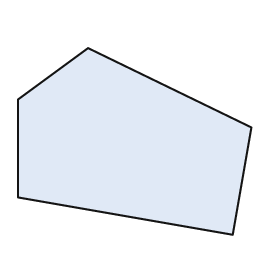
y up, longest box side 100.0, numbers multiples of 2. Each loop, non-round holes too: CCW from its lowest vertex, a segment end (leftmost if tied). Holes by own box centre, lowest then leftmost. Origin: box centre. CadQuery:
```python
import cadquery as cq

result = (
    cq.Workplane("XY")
    .moveTo(42.0, -40.0)
    .lineTo(50.0, 6.0)
    .lineTo(-20.0, 40.0)
    .lineTo(-50.0, 18.0)
    .lineTo(-50.0, -24.0)
    .close()
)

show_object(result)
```